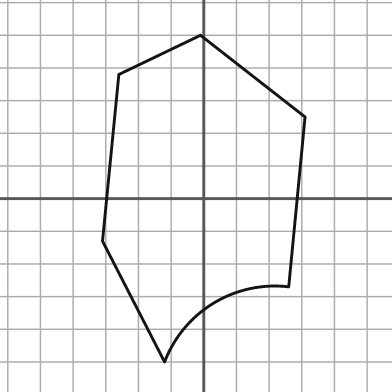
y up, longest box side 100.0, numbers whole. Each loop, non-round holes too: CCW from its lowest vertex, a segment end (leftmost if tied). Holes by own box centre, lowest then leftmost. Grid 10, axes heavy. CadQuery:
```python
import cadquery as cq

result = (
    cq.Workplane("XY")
    .moveTo(-12.0, -50.0)
    .threePointArc((3.0, -32.0), (26.0, -27.0))
    .lineTo(31.0, 25.0)
    .lineTo(-1.0, 50.0)
    .lineTo(-26.0, 38.0)
    .lineTo(-31.0, -13.0)
    .close()
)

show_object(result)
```